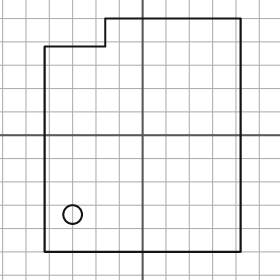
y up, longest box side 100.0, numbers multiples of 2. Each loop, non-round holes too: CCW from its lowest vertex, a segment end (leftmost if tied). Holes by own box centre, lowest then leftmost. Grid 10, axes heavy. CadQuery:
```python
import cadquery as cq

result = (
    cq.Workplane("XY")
    .moveTo(-42.0, -50.0)
    .lineTo(42.0, -50.0)
    .lineTo(42.0, 50.0)
    .lineTo(-16.0, 50.0)
    .lineTo(-16.0, 38.0)
    .lineTo(-42.0, 38.0)
    .close()
    .moveTo(-30.0, -34.0)
    .circle(4.0)
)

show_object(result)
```